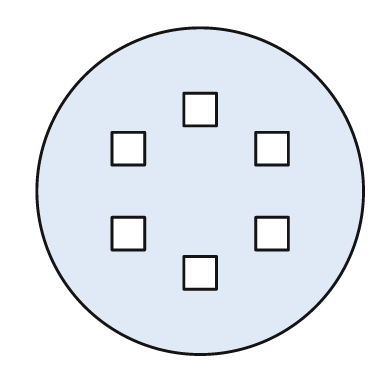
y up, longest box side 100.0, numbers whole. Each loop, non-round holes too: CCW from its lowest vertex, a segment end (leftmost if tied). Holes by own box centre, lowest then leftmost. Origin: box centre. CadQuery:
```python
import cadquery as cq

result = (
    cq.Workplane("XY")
    .moveTo(0.0, 0.0)
    .circle(50.0)
    .moveTo(-5.0, -30.0)
    .lineTo(5.0, -30.0)
    .lineTo(5.0, -20.0)
    .lineTo(-5.0, -20.0)
    .close()
    .moveTo(-27.0, -18.0)
    .lineTo(-17.0, -18.0)
    .lineTo(-17.0, -8.0)
    .lineTo(-27.0, -8.0)
    .close()
    .moveTo(17.0, -18.0)
    .lineTo(27.0, -18.0)
    .lineTo(27.0, -8.0)
    .lineTo(17.0, -8.0)
    .close()
    .moveTo(-27.0, 8.0)
    .lineTo(-17.0, 8.0)
    .lineTo(-17.0, 18.0)
    .lineTo(-27.0, 18.0)
    .close()
    .moveTo(17.0, 8.0)
    .lineTo(27.0, 8.0)
    .lineTo(27.0, 18.0)
    .lineTo(17.0, 18.0)
    .close()
    .moveTo(-5.0, 20.0)
    .lineTo(5.0, 20.0)
    .lineTo(5.0, 30.0)
    .lineTo(-5.0, 30.0)
    .close()
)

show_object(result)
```